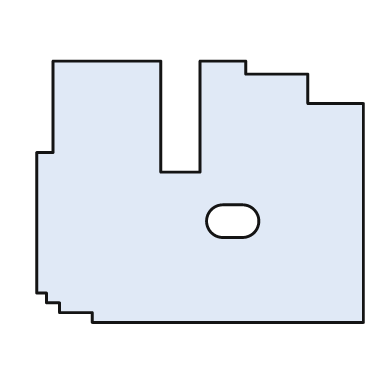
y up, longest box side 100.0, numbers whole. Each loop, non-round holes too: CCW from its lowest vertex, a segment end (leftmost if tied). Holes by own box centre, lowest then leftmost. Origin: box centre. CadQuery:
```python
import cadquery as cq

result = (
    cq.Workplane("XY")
    .moveTo(-33.0, -40.0)
    .lineTo(50.0, -40.0)
    .lineTo(50.0, 27.0)
    .lineTo(33.0, 27.0)
    .lineTo(33.0, 36.0)
    .lineTo(14.0, 36.0)
    .lineTo(14.0, 40.0)
    .lineTo(0.0, 40.0)
    .lineTo(0.0, 6.0)
    .lineTo(-12.0, 6.0)
    .lineTo(-12.0, 40.0)
    .lineTo(-45.0, 40.0)
    .lineTo(-45.0, 12.0)
    .lineTo(-50.0, 12.0)
    .lineTo(-50.0, -31.0)
    .lineTo(-47.0, -31.0)
    .lineTo(-47.0, -34.0)
    .lineTo(-43.0, -34.0)
    .lineTo(-43.0, -37.0)
    .lineTo(-33.0, -37.0)
    .close()
    .moveTo(7.0, -14.0)
    .lineTo(13.0, -14.0)
    .threePointArc((18.0, -9.0), (13.0, -4.0))
    .lineTo(7.0, -4.0)
    .threePointArc((2.0, -9.0), (7.0, -14.0))
    .close()
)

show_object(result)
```